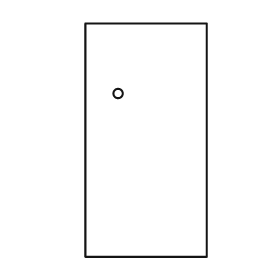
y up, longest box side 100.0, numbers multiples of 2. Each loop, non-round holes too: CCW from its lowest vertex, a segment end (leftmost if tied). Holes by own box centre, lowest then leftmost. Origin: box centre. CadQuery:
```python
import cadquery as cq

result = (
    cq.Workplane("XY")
    .moveTo(-26.0, -50.0)
    .lineTo(26.0, -50.0)
    .lineTo(26.0, 50.0)
    .lineTo(-26.0, 50.0)
    .close()
    .moveTo(-12.0, 20.0)
    .circle(2.0)
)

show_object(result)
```